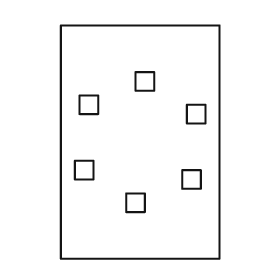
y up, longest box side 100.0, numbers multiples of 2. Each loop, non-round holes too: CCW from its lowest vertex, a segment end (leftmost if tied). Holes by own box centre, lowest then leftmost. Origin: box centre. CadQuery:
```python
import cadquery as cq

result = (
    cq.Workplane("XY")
    .moveTo(-34.0, -50.0)
    .lineTo(34.0, -50.0)
    .lineTo(34.0, 50.0)
    .lineTo(-34.0, 50.0)
    .close()
    .moveTo(-6.0, -30.0)
    .lineTo(2.0, -30.0)
    .lineTo(2.0, -22.0)
    .lineTo(-6.0, -22.0)
    .close()
    .moveTo(18.0, -20.0)
    .lineTo(26.0, -20.0)
    .lineTo(26.0, -12.0)
    .lineTo(18.0, -12.0)
    .close()
    .moveTo(-28.0, -16.0)
    .lineTo(-20.0, -16.0)
    .lineTo(-20.0, -8.0)
    .lineTo(-28.0, -8.0)
    .close()
    .moveTo(20.0, 8.0)
    .lineTo(28.0, 8.0)
    .lineTo(28.0, 16.0)
    .lineTo(20.0, 16.0)
    .close()
    .moveTo(-26.0, 12.0)
    .lineTo(-18.0, 12.0)
    .lineTo(-18.0, 20.0)
    .lineTo(-26.0, 20.0)
    .close()
    .moveTo(-2.0, 22.0)
    .lineTo(6.0, 22.0)
    .lineTo(6.0, 30.0)
    .lineTo(-2.0, 30.0)
    .close()
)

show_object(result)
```